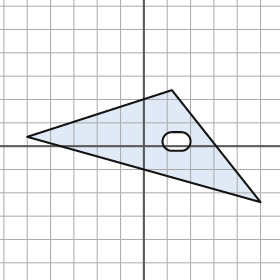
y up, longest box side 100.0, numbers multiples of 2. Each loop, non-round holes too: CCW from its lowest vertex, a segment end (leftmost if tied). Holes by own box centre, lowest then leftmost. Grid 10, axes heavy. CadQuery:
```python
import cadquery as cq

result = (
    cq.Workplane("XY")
    .moveTo(50.0, -24.0)
    .lineTo(12.0, 24.0)
    .lineTo(-50.0, 4.0)
    .close()
    .moveTo(12.0, -2.0)
    .lineTo(16.0, -2.0)
    .threePointArc((20.0, 2.0), (16.0, 6.0))
    .lineTo(12.0, 6.0)
    .threePointArc((8.0, 2.0), (12.0, -2.0))
    .close()
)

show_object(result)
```